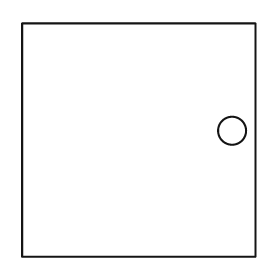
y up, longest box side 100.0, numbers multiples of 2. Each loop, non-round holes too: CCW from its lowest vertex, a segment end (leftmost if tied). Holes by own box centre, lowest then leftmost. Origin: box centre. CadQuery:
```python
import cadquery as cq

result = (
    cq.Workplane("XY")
    .moveTo(-50.0, -50.0)
    .lineTo(50.0, -50.0)
    .lineTo(50.0, 50.0)
    .lineTo(-50.0, 50.0)
    .close()
    .moveTo(40.0, 4.0)
    .circle(6.0)
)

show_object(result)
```